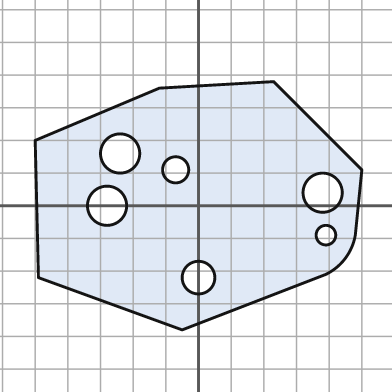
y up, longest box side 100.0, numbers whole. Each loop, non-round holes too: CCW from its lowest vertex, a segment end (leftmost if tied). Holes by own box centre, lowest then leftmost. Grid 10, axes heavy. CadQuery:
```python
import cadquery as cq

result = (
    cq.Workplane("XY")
    .moveTo(-5.0, -38.0)
    .lineTo(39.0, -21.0)
    .threePointArc((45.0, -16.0), (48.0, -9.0))
    .lineTo(50.0, 11.0)
    .lineTo(23.0, 38.0)
    .lineTo(-12.0, 36.0)
    .lineTo(-50.0, 20.0)
    .lineTo(-49.0, -22.0)
    .close()
    .moveTo(0.0, -22.0)
    .circle(5.0)
    .moveTo(39.0, -9.0)
    .circle(3.0)
    .moveTo(-28.0, 0.0)
    .circle(6.0)
    .moveTo(38.0, 4.0)
    .circle(6.0)
    .moveTo(-7.0, 11.0)
    .circle(4.0)
    .moveTo(-24.0, 16.0)
    .circle(6.0)
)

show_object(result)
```